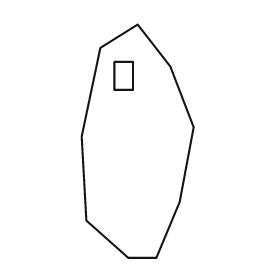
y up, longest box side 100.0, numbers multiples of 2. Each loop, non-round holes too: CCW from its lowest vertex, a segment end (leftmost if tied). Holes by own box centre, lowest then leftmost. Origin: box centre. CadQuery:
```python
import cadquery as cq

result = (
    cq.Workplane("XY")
    .moveTo(-4.0, -50.0)
    .lineTo(8.0, -50.0)
    .lineTo(18.0, -26.0)
    .lineTo(24.0, 6.0)
    .lineTo(14.0, 32.0)
    .lineTo(0.0, 50.0)
    .lineTo(-16.0, 40.0)
    .lineTo(-24.0, 2.0)
    .lineTo(-22.0, -34.0)
    .close()
    .moveTo(-10.0, 22.0)
    .lineTo(-2.0, 22.0)
    .lineTo(-2.0, 34.0)
    .lineTo(-10.0, 34.0)
    .close()
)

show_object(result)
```